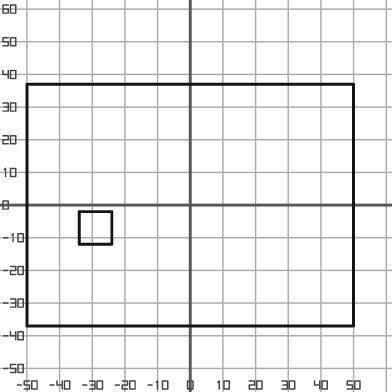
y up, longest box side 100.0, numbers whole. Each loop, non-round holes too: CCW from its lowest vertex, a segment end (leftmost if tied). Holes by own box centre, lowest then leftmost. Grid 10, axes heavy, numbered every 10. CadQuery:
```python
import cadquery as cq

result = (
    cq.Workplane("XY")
    .moveTo(-50.0, -37.0)
    .lineTo(50.0, -37.0)
    .lineTo(50.0, 37.0)
    .lineTo(-50.0, 37.0)
    .close()
    .moveTo(-34.0, -12.0)
    .lineTo(-24.0, -12.0)
    .lineTo(-24.0, -2.0)
    .lineTo(-34.0, -2.0)
    .close()
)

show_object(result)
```